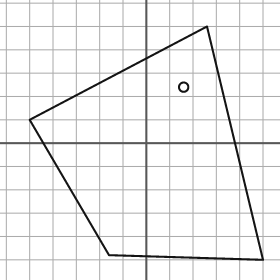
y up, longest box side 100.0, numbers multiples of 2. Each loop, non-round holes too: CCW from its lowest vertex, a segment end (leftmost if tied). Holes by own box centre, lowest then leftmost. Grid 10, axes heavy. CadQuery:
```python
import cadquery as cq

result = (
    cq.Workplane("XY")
    .moveTo(50.0, -50.0)
    .lineTo(26.0, 50.0)
    .lineTo(-50.0, 10.0)
    .lineTo(-16.0, -48.0)
    .close()
    .moveTo(16.0, 24.0)
    .circle(2.0)
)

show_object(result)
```